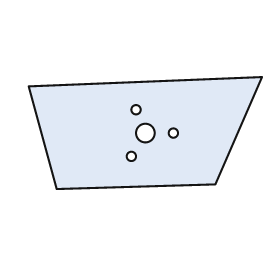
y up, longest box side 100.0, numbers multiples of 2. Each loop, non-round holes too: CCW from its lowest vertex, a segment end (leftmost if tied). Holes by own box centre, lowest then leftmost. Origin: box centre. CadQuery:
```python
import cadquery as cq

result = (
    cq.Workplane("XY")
    .moveTo(-38.0, -24.0)
    .lineTo(30.0, -22.0)
    .lineTo(50.0, 24.0)
    .lineTo(-50.0, 20.0)
    .close()
    .moveTo(-6.0, -10.0)
    .circle(2.0)
    .moveTo(0.0, 0.0)
    .circle(4.0)
    .moveTo(12.0, 0.0)
    .circle(2.0)
    .moveTo(-4.0, 10.0)
    .circle(2.0)
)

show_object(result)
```